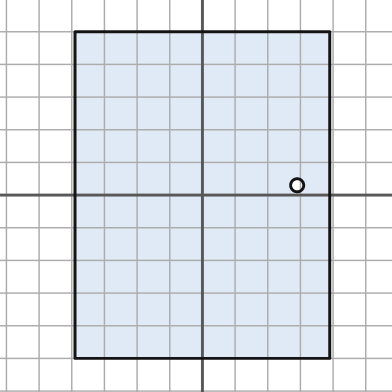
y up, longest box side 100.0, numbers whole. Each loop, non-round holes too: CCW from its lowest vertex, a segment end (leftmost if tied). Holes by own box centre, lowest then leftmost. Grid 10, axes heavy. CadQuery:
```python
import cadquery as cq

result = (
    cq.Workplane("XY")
    .moveTo(-39.0, -50.0)
    .lineTo(39.0, -50.0)
    .lineTo(39.0, 50.0)
    .lineTo(-39.0, 50.0)
    .close()
    .moveTo(29.0, 3.0)
    .circle(2.0)
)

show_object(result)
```